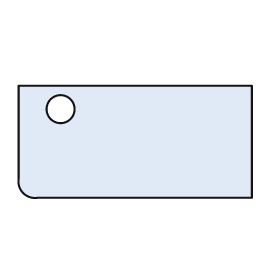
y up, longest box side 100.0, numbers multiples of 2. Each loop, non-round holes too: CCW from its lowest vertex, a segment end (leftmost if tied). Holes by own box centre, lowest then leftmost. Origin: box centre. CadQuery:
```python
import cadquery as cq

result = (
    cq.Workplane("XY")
    .moveTo(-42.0, -24.0)
    .lineTo(50.0, -24.0)
    .lineTo(50.0, 24.0)
    .lineTo(-50.0, 24.0)
    .lineTo(-50.0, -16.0)
    .threePointArc((-48.0, -22.0), (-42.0, -24.0))
    .close()
    .moveTo(-32.0, 14.0)
    .circle(6.0)
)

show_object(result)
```